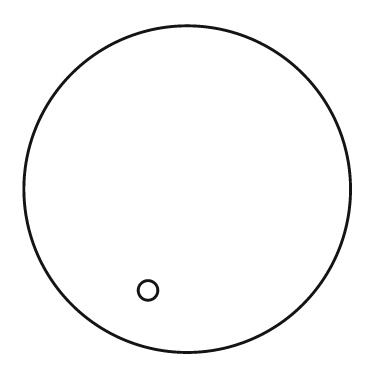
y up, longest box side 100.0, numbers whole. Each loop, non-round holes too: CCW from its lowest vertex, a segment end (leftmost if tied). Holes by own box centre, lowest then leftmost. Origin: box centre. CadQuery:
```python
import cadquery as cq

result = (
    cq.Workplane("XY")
    .moveTo(0.0, 0.0)
    .circle(50.0)
    .moveTo(-12.0, -31.0)
    .circle(3.0)
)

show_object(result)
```